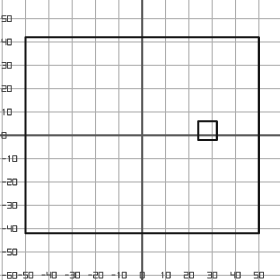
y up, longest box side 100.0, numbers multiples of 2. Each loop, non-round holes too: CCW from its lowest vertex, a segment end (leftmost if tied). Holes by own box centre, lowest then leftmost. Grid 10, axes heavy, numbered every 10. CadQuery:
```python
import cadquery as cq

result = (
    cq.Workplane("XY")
    .moveTo(-50.0, -42.0)
    .lineTo(50.0, -42.0)
    .lineTo(50.0, 42.0)
    .lineTo(-50.0, 42.0)
    .close()
    .moveTo(24.0, -2.0)
    .lineTo(32.0, -2.0)
    .lineTo(32.0, 6.0)
    .lineTo(24.0, 6.0)
    .close()
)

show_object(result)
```